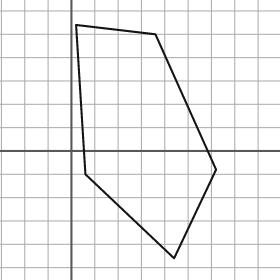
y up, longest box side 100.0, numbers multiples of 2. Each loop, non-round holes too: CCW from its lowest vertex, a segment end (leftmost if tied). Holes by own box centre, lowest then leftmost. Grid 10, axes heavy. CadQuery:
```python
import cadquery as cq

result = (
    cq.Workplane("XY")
    .moveTo(44.0, -46.0)
    .lineTo(62.0, -8.0)
    .lineTo(36.0, 50.0)
    .lineTo(2.0, 54.0)
    .lineTo(6.0, -10.0)
    .close()
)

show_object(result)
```